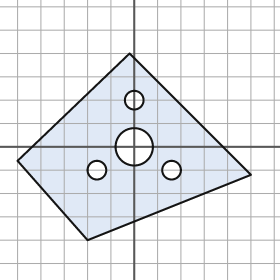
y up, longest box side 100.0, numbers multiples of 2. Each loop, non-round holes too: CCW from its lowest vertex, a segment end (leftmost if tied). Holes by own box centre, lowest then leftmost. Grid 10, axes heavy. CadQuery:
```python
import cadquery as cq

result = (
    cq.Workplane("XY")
    .moveTo(-20.0, -40.0)
    .lineTo(50.0, -12.0)
    .lineTo(-2.0, 40.0)
    .lineTo(-50.0, -6.0)
    .close()
    .moveTo(-16.0, -10.0)
    .circle(4.0)
    .moveTo(16.0, -10.0)
    .circle(4.0)
    .moveTo(0.0, 0.0)
    .circle(8.0)
    .moveTo(0.0, 20.0)
    .circle(4.0)
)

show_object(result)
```